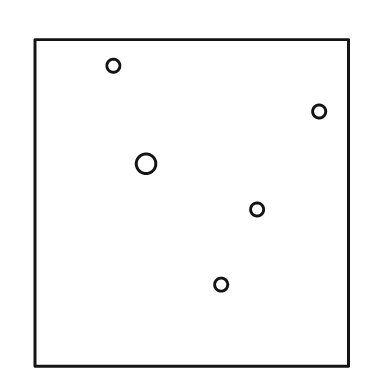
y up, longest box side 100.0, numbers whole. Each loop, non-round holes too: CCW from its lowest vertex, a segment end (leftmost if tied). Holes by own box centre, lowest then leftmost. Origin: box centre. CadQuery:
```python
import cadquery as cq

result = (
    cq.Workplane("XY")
    .moveTo(-48.0, -50.0)
    .lineTo(48.0, -50.0)
    .lineTo(48.0, 50.0)
    .lineTo(-48.0, 50.0)
    .close()
    .moveTo(9.0, -25.0)
    .circle(2.0)
    .moveTo(20.0, -2.0)
    .circle(2.0)
    .moveTo(-14.0, 12.0)
    .circle(3.0)
    .moveTo(39.0, 28.0)
    .circle(2.0)
    .moveTo(-24.0, 42.0)
    .circle(2.0)
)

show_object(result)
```